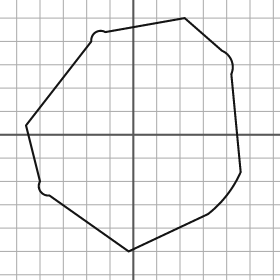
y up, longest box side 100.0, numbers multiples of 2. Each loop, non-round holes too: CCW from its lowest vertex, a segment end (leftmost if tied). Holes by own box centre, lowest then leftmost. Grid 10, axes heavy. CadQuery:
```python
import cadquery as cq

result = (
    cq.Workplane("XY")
    .moveTo(-2.0, -50.0)
    .lineTo(32.0, -34.0)
    .threePointArc((40.0, -26.0), (46.0, -16.0))
    .lineTo(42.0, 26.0)
    .threePointArc((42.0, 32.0), (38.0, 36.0))
    .lineTo(22.0, 50.0)
    .lineTo(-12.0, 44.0)
    .threePointArc((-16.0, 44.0), (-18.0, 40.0))
    .lineTo(-46.0, 4.0)
    .lineTo(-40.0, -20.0)
    .threePointArc((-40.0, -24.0), (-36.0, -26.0))
    .close()
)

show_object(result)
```